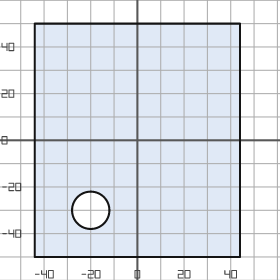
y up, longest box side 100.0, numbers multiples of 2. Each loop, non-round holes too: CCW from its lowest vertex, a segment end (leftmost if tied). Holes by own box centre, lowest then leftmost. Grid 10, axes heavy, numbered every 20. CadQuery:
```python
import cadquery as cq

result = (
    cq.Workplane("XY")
    .moveTo(-44.0, -50.0)
    .lineTo(44.0, -50.0)
    .lineTo(44.0, 50.0)
    .lineTo(-44.0, 50.0)
    .close()
    .moveTo(-20.0, -30.0)
    .circle(8.0)
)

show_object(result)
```